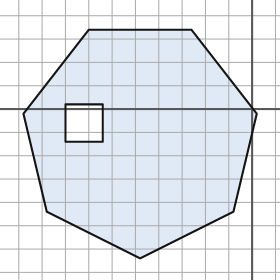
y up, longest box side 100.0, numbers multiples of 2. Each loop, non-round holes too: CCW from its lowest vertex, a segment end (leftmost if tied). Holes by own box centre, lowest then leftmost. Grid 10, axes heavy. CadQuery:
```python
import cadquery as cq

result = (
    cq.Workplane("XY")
    .moveTo(-48.0, -64.0)
    .lineTo(-8.0, -44.0)
    .lineTo(2.0, -2.0)
    .lineTo(-26.0, 34.0)
    .lineTo(-70.0, 34.0)
    .lineTo(-98.0, -2.0)
    .lineTo(-88.0, -44.0)
    .close()
    .moveTo(-80.0, -14.0)
    .lineTo(-64.0, -14.0)
    .lineTo(-64.0, 2.0)
    .lineTo(-80.0, 2.0)
    .close()
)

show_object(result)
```